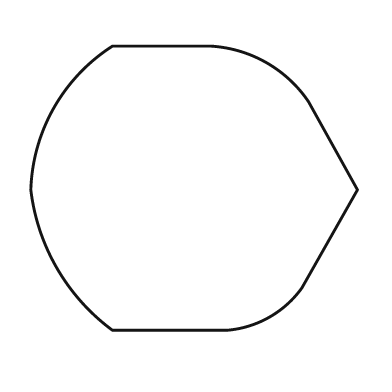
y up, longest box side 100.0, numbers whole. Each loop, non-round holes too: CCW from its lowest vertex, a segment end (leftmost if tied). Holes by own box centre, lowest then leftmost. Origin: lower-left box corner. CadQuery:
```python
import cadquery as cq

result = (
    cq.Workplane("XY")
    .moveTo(25.0, 0.0)
    .lineTo(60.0, 0.0)
    .threePointArc((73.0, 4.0), (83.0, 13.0))
    .lineTo(100.0, 43.0)
    .lineTo(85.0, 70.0)
    .threePointArc((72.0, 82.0), (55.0, 87.0))
    .lineTo(25.0, 87.0)
    .threePointArc((7.0, 68.0), (0.0, 43.0))
    .threePointArc((8.0, 19.0), (25.0, 0.0))
    .close()
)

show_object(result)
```